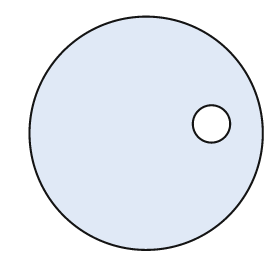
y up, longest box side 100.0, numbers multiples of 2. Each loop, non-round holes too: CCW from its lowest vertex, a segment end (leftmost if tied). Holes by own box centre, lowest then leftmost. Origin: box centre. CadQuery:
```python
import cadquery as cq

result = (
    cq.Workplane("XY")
    .moveTo(0.0, 0.0)
    .circle(50.0)
    .moveTo(28.0, 4.0)
    .circle(8.0)
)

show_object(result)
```